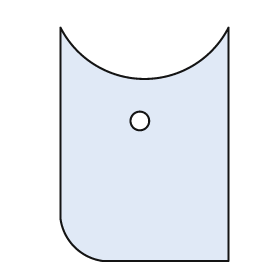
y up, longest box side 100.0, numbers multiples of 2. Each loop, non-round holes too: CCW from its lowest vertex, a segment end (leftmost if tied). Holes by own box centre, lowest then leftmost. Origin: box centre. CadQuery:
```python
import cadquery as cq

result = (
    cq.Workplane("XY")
    .moveTo(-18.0, -50.0)
    .lineTo(36.0, -50.0)
    .lineTo(36.0, 50.0)
    .threePointArc((0.0, 28.0), (-36.0, 50.0))
    .lineTo(-36.0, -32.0)
    .threePointArc((-30.0, -44.0), (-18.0, -50.0))
    .close()
    .moveTo(-2.0, 10.0)
    .circle(4.0)
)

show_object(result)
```